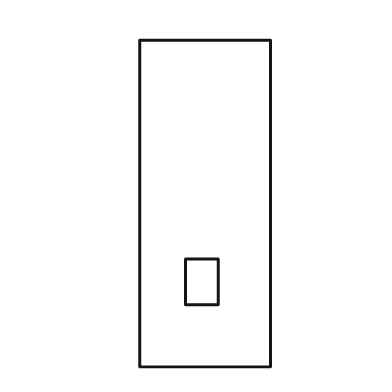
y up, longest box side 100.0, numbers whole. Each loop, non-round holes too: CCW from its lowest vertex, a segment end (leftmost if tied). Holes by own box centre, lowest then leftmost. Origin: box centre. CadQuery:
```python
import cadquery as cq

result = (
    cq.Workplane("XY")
    .moveTo(-20.0, -50.0)
    .lineTo(20.0, -50.0)
    .lineTo(20.0, 50.0)
    .lineTo(-20.0, 50.0)
    .close()
    .moveTo(-6.0, -31.0)
    .lineTo(4.0, -31.0)
    .lineTo(4.0, -17.0)
    .lineTo(-6.0, -17.0)
    .close()
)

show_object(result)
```